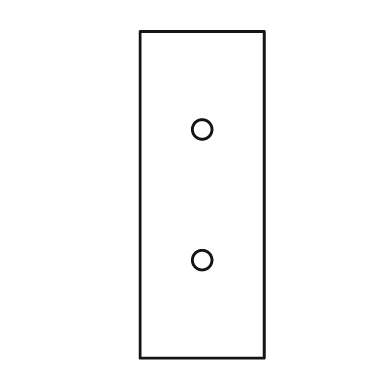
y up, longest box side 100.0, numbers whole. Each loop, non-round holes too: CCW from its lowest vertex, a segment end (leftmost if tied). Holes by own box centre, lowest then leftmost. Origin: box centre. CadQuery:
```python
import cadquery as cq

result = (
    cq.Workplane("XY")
    .moveTo(-19.0, -50.0)
    .lineTo(19.0, -50.0)
    .lineTo(19.0, 50.0)
    .lineTo(-19.0, 50.0)
    .close()
    .moveTo(0.0, -20.0)
    .circle(3.0)
    .moveTo(0.0, 20.0)
    .circle(3.0)
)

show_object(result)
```